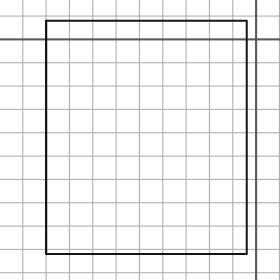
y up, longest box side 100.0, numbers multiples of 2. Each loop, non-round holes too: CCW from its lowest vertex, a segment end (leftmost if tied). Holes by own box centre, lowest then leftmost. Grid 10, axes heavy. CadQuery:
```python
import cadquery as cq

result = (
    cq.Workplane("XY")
    .moveTo(-90.0, -92.0)
    .lineTo(-4.0, -92.0)
    .lineTo(-4.0, 8.0)
    .lineTo(-90.0, 8.0)
    .close()
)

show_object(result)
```